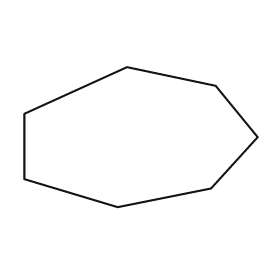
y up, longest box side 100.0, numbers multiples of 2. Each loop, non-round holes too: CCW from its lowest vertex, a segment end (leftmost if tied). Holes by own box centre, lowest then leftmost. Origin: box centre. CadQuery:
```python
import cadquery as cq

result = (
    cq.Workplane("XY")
    .moveTo(-10.0, -30.0)
    .lineTo(30.0, -22.0)
    .lineTo(50.0, 0.0)
    .lineTo(32.0, 22.0)
    .lineTo(-6.0, 30.0)
    .lineTo(-50.0, 10.0)
    .lineTo(-50.0, -18.0)
    .close()
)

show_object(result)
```